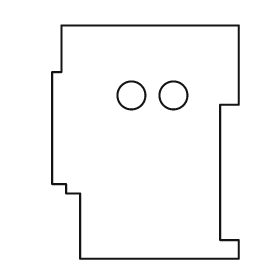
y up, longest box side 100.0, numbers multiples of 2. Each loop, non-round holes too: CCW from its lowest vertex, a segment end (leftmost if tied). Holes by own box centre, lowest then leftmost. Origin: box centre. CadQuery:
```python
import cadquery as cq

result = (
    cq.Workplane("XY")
    .moveTo(-28.0, -50.0)
    .lineTo(40.0, -50.0)
    .lineTo(40.0, -42.0)
    .lineTo(32.0, -42.0)
    .lineTo(32.0, 16.0)
    .lineTo(40.0, 16.0)
    .lineTo(40.0, 50.0)
    .lineTo(-36.0, 50.0)
    .lineTo(-36.0, 30.0)
    .lineTo(-40.0, 30.0)
    .lineTo(-40.0, -18.0)
    .lineTo(-34.0, -18.0)
    .lineTo(-34.0, -22.0)
    .lineTo(-28.0, -22.0)
    .close()
    .moveTo(-6.0, 20.0)
    .circle(6.0)
    .moveTo(12.0, 20.0)
    .circle(6.0)
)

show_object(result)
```